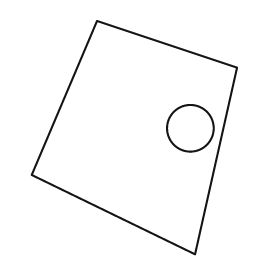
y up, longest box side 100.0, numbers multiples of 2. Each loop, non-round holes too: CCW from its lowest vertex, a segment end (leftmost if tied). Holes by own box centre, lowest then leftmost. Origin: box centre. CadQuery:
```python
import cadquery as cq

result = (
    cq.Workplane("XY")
    .moveTo(26.0, -50.0)
    .lineTo(44.0, 30.0)
    .lineTo(-16.0, 50.0)
    .lineTo(-44.0, -16.0)
    .close()
    .moveTo(24.0, 4.0)
    .circle(10.0)
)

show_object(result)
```